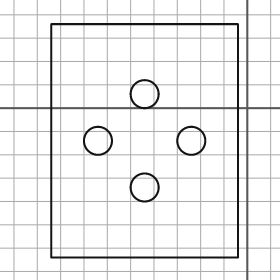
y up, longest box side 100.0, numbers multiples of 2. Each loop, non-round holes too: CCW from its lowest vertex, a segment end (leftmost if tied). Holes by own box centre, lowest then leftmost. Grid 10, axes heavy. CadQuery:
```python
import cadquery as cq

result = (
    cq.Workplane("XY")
    .moveTo(-84.0, -64.0)
    .lineTo(-4.0, -64.0)
    .lineTo(-4.0, 36.0)
    .lineTo(-84.0, 36.0)
    .close()
    .moveTo(-44.0, -34.0)
    .circle(6.0)
    .moveTo(-64.0, -14.0)
    .circle(6.0)
    .moveTo(-24.0, -14.0)
    .circle(6.0)
    .moveTo(-44.0, 6.0)
    .circle(6.0)
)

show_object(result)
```